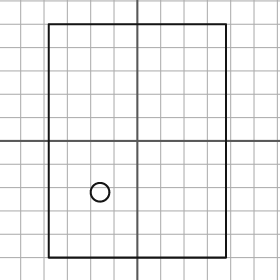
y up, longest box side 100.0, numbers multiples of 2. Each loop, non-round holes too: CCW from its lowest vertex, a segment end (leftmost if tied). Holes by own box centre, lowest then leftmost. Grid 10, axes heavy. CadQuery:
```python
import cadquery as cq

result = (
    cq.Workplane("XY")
    .moveTo(-38.0, -50.0)
    .lineTo(38.0, -50.0)
    .lineTo(38.0, 50.0)
    .lineTo(-38.0, 50.0)
    .close()
    .moveTo(-16.0, -22.0)
    .circle(4.0)
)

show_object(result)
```